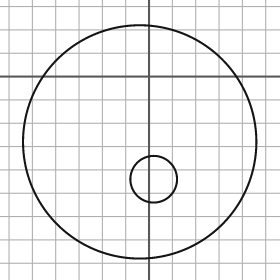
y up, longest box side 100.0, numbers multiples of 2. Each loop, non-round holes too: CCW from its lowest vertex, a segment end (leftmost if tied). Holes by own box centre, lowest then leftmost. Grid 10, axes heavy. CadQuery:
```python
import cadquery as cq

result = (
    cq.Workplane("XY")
    .moveTo(-4.0, -28.0)
    .circle(50.0)
    .moveTo(2.0, -44.0)
    .circle(10.0)
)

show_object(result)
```